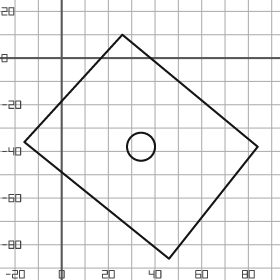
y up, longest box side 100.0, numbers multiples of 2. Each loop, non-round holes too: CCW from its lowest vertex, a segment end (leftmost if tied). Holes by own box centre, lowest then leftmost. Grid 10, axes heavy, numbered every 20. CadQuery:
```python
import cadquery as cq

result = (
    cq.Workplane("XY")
    .moveTo(46.0, -86.0)
    .lineTo(84.0, -38.0)
    .lineTo(26.0, 10.0)
    .lineTo(-16.0, -36.0)
    .close()
    .moveTo(34.0, -38.0)
    .circle(6.0)
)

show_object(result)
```